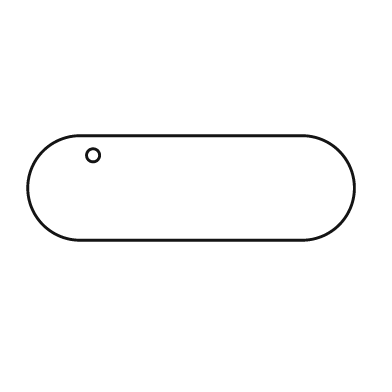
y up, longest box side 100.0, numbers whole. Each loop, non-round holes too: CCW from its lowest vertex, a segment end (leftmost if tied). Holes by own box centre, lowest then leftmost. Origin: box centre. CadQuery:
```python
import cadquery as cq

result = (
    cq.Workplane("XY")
    .moveTo(-34.0, -16.0)
    .lineTo(34.0, -16.0)
    .threePointArc((50.0, 0.0), (34.0, 16.0))
    .lineTo(-34.0, 16.0)
    .threePointArc((-50.0, 0.0), (-34.0, -16.0))
    .close()
    .moveTo(-30.0, 10.0)
    .circle(2.0)
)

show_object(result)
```